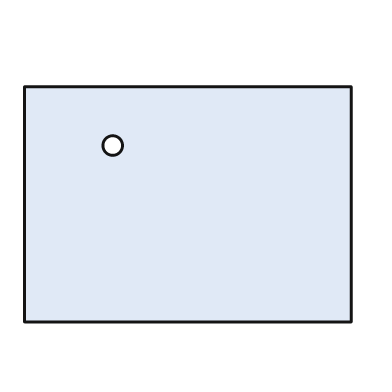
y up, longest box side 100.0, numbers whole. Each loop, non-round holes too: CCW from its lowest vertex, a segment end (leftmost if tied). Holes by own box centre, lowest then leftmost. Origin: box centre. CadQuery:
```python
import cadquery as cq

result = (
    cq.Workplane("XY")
    .moveTo(-50.0, -36.0)
    .lineTo(50.0, -36.0)
    .lineTo(50.0, 36.0)
    .lineTo(-50.0, 36.0)
    .close()
    .moveTo(-23.0, 18.0)
    .circle(3.0)
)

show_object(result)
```